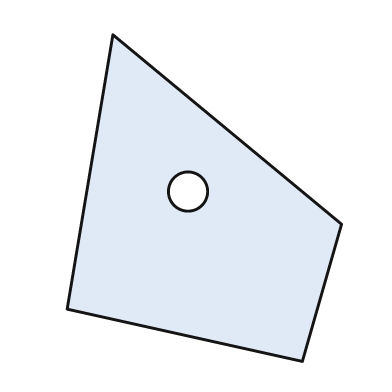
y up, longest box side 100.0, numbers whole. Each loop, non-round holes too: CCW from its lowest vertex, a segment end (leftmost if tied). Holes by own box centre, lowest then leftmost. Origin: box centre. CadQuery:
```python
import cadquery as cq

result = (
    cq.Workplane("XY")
    .moveTo(30.0, -50.0)
    .lineTo(42.0, -8.0)
    .lineTo(-28.0, 50.0)
    .lineTo(-42.0, -34.0)
    .close()
    .moveTo(-5.0, 2.0)
    .circle(6.0)
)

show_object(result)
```